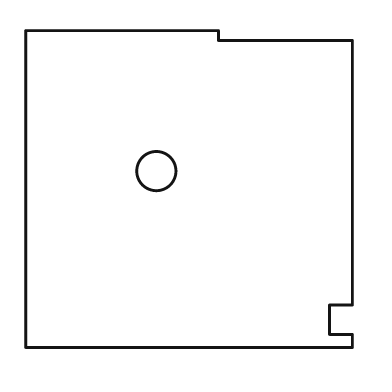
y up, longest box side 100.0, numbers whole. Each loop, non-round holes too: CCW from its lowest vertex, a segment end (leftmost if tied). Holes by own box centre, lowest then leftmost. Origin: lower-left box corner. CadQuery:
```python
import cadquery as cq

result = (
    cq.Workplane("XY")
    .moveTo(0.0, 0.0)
    .lineTo(100.0, 0.0)
    .lineTo(100.0, 4.0)
    .lineTo(93.0, 4.0)
    .lineTo(93.0, 13.0)
    .lineTo(100.0, 13.0)
    .lineTo(100.0, 94.0)
    .lineTo(59.0, 94.0)
    .lineTo(59.0, 97.0)
    .lineTo(0.0, 97.0)
    .close()
    .moveTo(40.0, 54.0)
    .circle(6.0)
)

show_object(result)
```